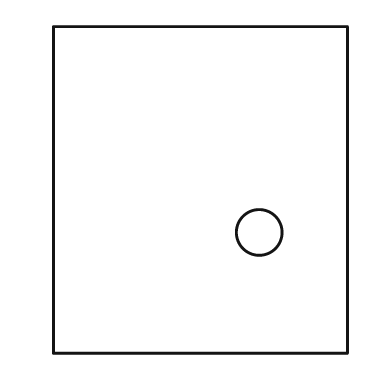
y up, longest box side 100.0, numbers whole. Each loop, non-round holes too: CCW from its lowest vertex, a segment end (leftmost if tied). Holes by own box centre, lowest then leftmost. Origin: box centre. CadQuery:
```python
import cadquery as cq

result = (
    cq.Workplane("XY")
    .moveTo(-45.0, -50.0)
    .lineTo(45.0, -50.0)
    .lineTo(45.0, 50.0)
    .lineTo(-45.0, 50.0)
    .close()
    .moveTo(18.0, -13.0)
    .circle(7.0)
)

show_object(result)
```